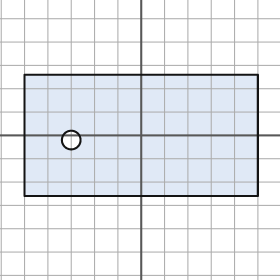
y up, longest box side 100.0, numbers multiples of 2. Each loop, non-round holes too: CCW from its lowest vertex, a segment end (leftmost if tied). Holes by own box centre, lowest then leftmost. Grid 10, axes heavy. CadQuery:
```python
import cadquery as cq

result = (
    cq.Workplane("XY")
    .moveTo(-50.0, -26.0)
    .lineTo(50.0, -26.0)
    .lineTo(50.0, 26.0)
    .lineTo(-50.0, 26.0)
    .close()
    .moveTo(-30.0, -2.0)
    .circle(4.0)
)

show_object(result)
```